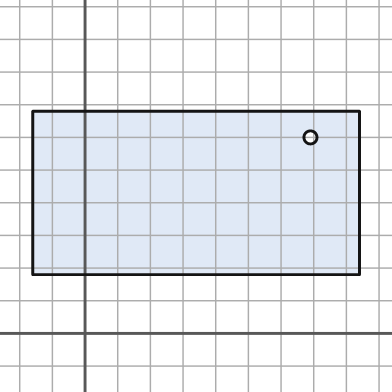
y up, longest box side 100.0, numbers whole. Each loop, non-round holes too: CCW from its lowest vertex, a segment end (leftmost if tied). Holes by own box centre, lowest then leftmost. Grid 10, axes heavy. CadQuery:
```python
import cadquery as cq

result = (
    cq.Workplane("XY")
    .moveTo(-16.0, 18.0)
    .lineTo(84.0, 18.0)
    .lineTo(84.0, 68.0)
    .lineTo(-16.0, 68.0)
    .close()
    .moveTo(69.0, 60.0)
    .circle(2.0)
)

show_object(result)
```